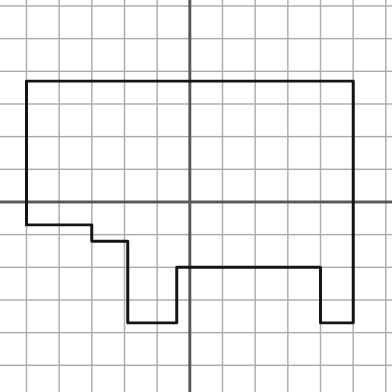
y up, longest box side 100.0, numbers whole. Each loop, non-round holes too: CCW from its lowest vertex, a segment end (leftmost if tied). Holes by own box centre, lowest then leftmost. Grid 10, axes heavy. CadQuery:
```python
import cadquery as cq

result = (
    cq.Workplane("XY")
    .moveTo(-19.0, -37.0)
    .lineTo(-4.0, -37.0)
    .lineTo(-4.0, -20.0)
    .lineTo(40.0, -20.0)
    .lineTo(40.0, -37.0)
    .lineTo(50.0, -37.0)
    .lineTo(50.0, 37.0)
    .lineTo(-50.0, 37.0)
    .lineTo(-50.0, -7.0)
    .lineTo(-30.0, -7.0)
    .lineTo(-30.0, -12.0)
    .lineTo(-19.0, -12.0)
    .close()
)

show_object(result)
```